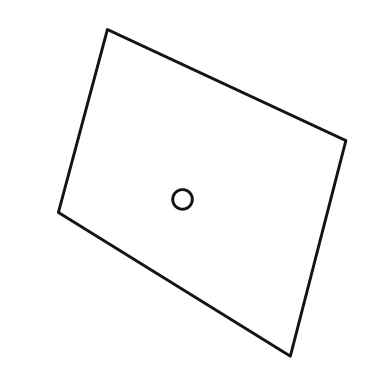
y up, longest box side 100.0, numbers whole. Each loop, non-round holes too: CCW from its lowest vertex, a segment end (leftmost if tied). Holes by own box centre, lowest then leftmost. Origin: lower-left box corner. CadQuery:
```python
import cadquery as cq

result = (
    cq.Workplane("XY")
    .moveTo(71.0, 0.0)
    .lineTo(88.0, 66.0)
    .lineTo(15.0, 100.0)
    .lineTo(0.0, 44.0)
    .close()
    .moveTo(38.0, 48.0)
    .circle(3.0)
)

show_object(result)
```